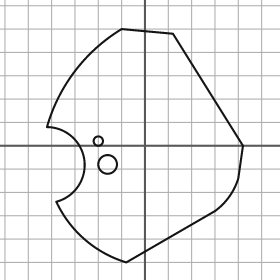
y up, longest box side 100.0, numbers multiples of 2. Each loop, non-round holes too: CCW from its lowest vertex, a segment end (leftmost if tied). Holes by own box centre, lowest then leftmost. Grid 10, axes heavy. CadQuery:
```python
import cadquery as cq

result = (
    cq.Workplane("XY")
    .moveTo(-8.0, -50.0)
    .lineTo(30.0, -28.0)
    .threePointArc((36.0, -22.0), (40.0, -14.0))
    .lineTo(42.0, 0.0)
    .lineTo(12.0, 48.0)
    .lineTo(-10.0, 50.0)
    .threePointArc((-30.0, 32.0), (-42.0, 8.0))
    .threePointArc((-26.0, -6.0), (-38.0, -24.0))
    .threePointArc((-26.0, -40.0), (-8.0, -50.0))
    .close()
    .moveTo(-16.0, -8.0)
    .circle(4.0)
    .moveTo(-20.0, 2.0)
    .circle(2.0)
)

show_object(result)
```